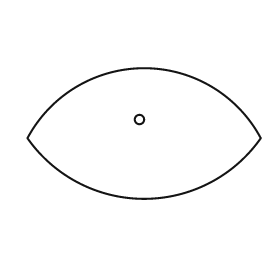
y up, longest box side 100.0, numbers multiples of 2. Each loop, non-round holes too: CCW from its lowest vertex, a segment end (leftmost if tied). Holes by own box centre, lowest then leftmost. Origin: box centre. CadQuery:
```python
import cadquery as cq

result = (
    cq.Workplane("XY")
    .moveTo(-50.0, -2.0)
    .threePointArc((0.0, -28.0), (50.0, -2.0))
    .threePointArc((0.0, 28.0), (-50.0, -2.0))
    .close()
    .moveTo(-2.0, 6.0)
    .circle(2.0)
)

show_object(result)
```